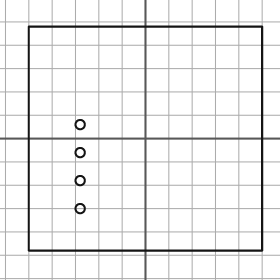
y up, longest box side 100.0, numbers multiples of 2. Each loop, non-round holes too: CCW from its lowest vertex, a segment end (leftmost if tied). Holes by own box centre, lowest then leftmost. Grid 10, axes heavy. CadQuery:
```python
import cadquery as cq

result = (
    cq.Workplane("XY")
    .moveTo(-50.0, -48.0)
    .lineTo(50.0, -48.0)
    .lineTo(50.0, 48.0)
    .lineTo(-50.0, 48.0)
    .close()
    .moveTo(-28.0, -30.0)
    .circle(2.0)
    .moveTo(-28.0, -18.0)
    .circle(2.0)
    .moveTo(-28.0, -6.0)
    .circle(2.0)
    .moveTo(-28.0, 6.0)
    .circle(2.0)
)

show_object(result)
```